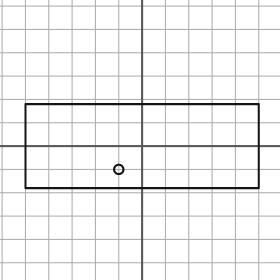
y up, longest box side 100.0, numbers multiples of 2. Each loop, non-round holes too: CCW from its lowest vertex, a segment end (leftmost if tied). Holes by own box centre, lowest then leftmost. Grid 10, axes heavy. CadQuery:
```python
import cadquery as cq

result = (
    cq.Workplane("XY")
    .moveTo(-50.0, -18.0)
    .lineTo(50.0, -18.0)
    .lineTo(50.0, 18.0)
    .lineTo(-50.0, 18.0)
    .close()
    .moveTo(-10.0, -10.0)
    .circle(2.0)
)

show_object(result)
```